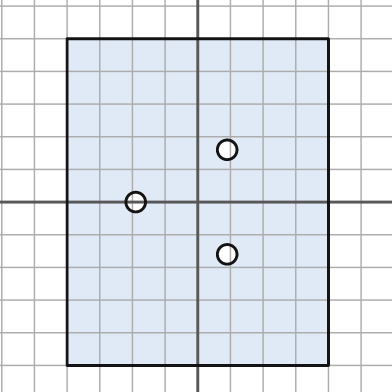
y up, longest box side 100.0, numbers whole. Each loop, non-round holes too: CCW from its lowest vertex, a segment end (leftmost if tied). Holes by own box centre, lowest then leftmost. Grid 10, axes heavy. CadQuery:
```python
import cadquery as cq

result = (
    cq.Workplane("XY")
    .moveTo(-40.0, -50.0)
    .lineTo(40.0, -50.0)
    .lineTo(40.0, 50.0)
    .lineTo(-40.0, 50.0)
    .close()
    .moveTo(9.0, -16.0)
    .circle(3.0)
    .moveTo(-19.0, 0.0)
    .circle(3.0)
    .moveTo(9.0, 16.0)
    .circle(3.0)
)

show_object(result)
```